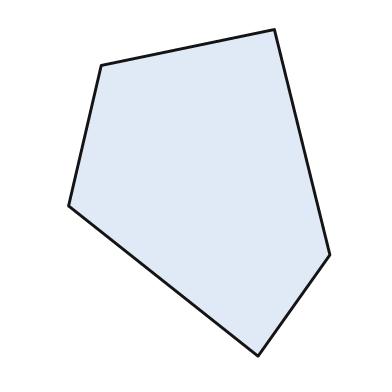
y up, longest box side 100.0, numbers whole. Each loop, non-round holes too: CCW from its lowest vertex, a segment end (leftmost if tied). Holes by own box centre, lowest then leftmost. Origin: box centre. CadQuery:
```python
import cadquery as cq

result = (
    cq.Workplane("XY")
    .moveTo(18.0, -50.0)
    .lineTo(40.0, -19.0)
    .lineTo(23.0, 50.0)
    .lineTo(-30.0, 39.0)
    .lineTo(-40.0, -4.0)
    .close()
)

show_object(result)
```